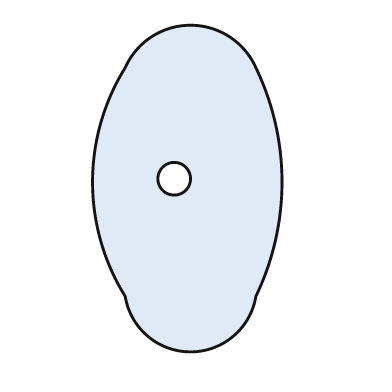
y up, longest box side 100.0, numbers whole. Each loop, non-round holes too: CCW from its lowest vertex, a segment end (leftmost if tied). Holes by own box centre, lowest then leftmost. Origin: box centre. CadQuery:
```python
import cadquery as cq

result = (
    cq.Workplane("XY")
    .moveTo(-19.0, -33.0)
    .threePointArc((1.0, -50.0), (21.0, -33.0))
    .threePointArc((29.0, 2.0), (21.0, 37.0))
    .threePointArc((1.0, 50.0), (-19.0, 37.0))
    .threePointArc((-29.0, 2.0), (-19.0, -33.0))
    .close()
    .moveTo(-4.0, 3.0)
    .circle(5.0)
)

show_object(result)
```